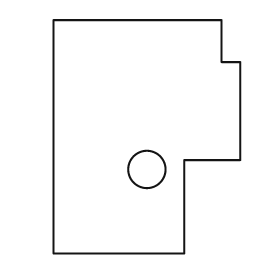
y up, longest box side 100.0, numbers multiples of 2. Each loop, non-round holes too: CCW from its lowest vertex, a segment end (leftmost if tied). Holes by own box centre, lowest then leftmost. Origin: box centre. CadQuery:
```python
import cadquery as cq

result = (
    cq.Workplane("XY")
    .moveTo(-40.0, -50.0)
    .lineTo(16.0, -50.0)
    .lineTo(16.0, -10.0)
    .lineTo(40.0, -10.0)
    .lineTo(40.0, 32.0)
    .lineTo(32.0, 32.0)
    .lineTo(32.0, 50.0)
    .lineTo(-40.0, 50.0)
    .close()
    .moveTo(0.0, -14.0)
    .circle(8.0)
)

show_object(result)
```